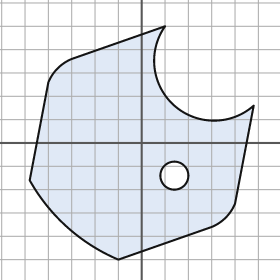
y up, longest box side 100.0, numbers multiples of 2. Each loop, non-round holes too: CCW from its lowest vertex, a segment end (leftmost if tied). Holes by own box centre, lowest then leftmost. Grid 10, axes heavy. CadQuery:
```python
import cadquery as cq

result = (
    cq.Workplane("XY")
    .moveTo(-10.0, -50.0)
    .lineTo(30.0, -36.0)
    .threePointArc((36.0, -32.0), (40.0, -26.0))
    .lineTo(48.0, 16.0)
    .threePointArc((14.0, 16.0), (10.0, 50.0))
    .lineTo(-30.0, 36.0)
    .threePointArc((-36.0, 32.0), (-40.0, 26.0))
    .lineTo(-48.0, -16.0)
    .threePointArc((-32.0, -36.0), (-10.0, -50.0))
    .close()
    .moveTo(14.0, -14.0)
    .circle(6.0)
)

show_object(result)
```